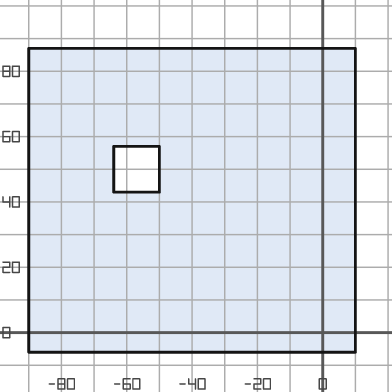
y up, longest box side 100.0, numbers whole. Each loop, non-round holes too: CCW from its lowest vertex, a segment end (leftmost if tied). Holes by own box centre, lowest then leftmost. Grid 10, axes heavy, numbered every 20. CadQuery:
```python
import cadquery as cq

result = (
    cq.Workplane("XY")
    .moveTo(-90.0, -6.0)
    .lineTo(10.0, -6.0)
    .lineTo(10.0, 87.0)
    .lineTo(-90.0, 87.0)
    .close()
    .moveTo(-64.0, 43.0)
    .lineTo(-50.0, 43.0)
    .lineTo(-50.0, 57.0)
    .lineTo(-64.0, 57.0)
    .close()
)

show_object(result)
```